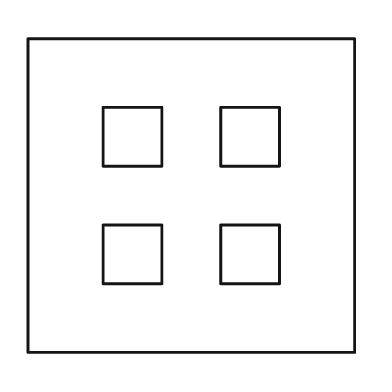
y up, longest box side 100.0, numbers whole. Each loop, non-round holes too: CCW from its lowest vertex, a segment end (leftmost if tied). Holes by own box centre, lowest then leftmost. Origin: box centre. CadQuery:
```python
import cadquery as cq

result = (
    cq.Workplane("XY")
    .moveTo(-50.0, -48.0)
    .lineTo(50.0, -48.0)
    .lineTo(50.0, 48.0)
    .lineTo(-50.0, 48.0)
    .close()
    .moveTo(-27.0, -27.0)
    .lineTo(-9.0, -27.0)
    .lineTo(-9.0, -9.0)
    .lineTo(-27.0, -9.0)
    .close()
    .moveTo(9.0, -27.0)
    .lineTo(27.0, -27.0)
    .lineTo(27.0, -9.0)
    .lineTo(9.0, -9.0)
    .close()
    .moveTo(-27.0, 9.0)
    .lineTo(-9.0, 9.0)
    .lineTo(-9.0, 27.0)
    .lineTo(-27.0, 27.0)
    .close()
    .moveTo(9.0, 9.0)
    .lineTo(27.0, 9.0)
    .lineTo(27.0, 27.0)
    .lineTo(9.0, 27.0)
    .close()
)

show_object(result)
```